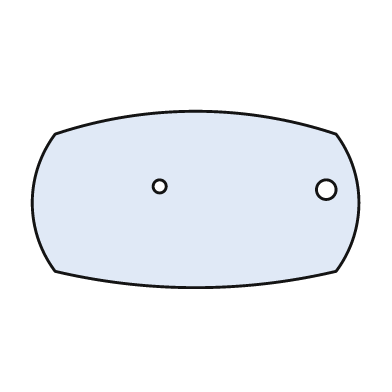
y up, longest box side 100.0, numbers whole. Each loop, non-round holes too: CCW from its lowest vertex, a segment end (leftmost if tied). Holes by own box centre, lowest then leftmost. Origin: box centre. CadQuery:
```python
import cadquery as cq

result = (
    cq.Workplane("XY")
    .moveTo(-43.0, -22.0)
    .threePointArc((0.0, -27.0), (43.0, -22.0))
    .threePointArc((50.0, -1.0), (43.0, 20.0))
    .threePointArc((0.0, 27.0), (-43.0, 20.0))
    .threePointArc((-50.0, -1.0), (-43.0, -22.0))
    .close()
    .moveTo(40.0, 3.0)
    .circle(3.0)
    .moveTo(-11.0, 4.0)
    .circle(2.0)
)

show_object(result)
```